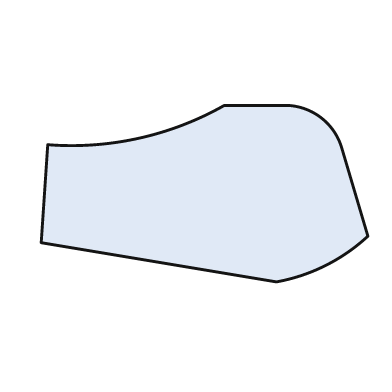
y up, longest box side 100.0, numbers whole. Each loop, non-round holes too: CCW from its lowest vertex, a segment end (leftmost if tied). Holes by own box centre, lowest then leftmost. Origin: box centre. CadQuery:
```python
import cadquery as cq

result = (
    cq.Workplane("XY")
    .moveTo(22.0, -27.0)
    .threePointArc((37.0, -22.0), (50.0, -13.0))
    .lineTo(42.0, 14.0)
    .threePointArc((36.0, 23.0), (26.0, 27.0))
    .lineTo(6.0, 27.0)
    .threePointArc((-20.0, 17.0), (-48.0, 15.0))
    .lineTo(-50.0, -15.0)
    .close()
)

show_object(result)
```